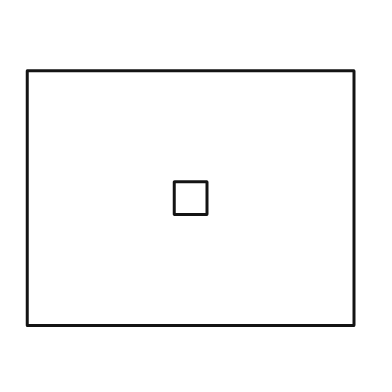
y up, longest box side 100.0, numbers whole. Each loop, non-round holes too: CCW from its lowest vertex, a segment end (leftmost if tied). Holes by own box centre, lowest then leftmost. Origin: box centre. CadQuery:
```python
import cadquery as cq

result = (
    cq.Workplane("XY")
    .moveTo(-50.0, -39.0)
    .lineTo(50.0, -39.0)
    .lineTo(50.0, 39.0)
    .lineTo(-50.0, 39.0)
    .close()
    .moveTo(-5.0, -5.0)
    .lineTo(5.0, -5.0)
    .lineTo(5.0, 5.0)
    .lineTo(-5.0, 5.0)
    .close()
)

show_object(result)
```